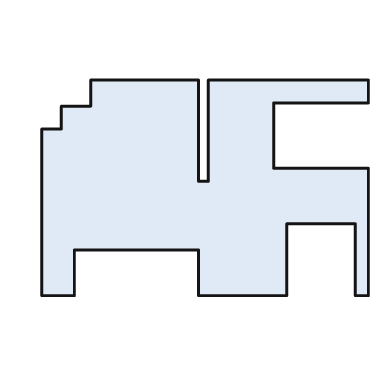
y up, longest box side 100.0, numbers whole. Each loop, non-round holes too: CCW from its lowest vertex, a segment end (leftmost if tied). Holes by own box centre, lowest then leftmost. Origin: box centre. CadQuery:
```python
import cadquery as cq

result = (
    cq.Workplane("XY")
    .moveTo(-50.0, -33.0)
    .lineTo(-40.0, -33.0)
    .lineTo(-40.0, -19.0)
    .lineTo(-2.0, -19.0)
    .lineTo(-2.0, -33.0)
    .lineTo(25.0, -33.0)
    .lineTo(25.0, -11.0)
    .lineTo(46.0, -11.0)
    .lineTo(46.0, -33.0)
    .lineTo(50.0, -33.0)
    .lineTo(50.0, 6.0)
    .lineTo(21.0, 6.0)
    .lineTo(21.0, 26.0)
    .lineTo(50.0, 26.0)
    .lineTo(50.0, 33.0)
    .lineTo(1.0, 33.0)
    .lineTo(1.0, 2.0)
    .lineTo(-2.0, 2.0)
    .lineTo(-2.0, 33.0)
    .lineTo(-35.0, 33.0)
    .lineTo(-35.0, 25.0)
    .lineTo(-44.0, 25.0)
    .lineTo(-44.0, 18.0)
    .lineTo(-50.0, 18.0)
    .close()
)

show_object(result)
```